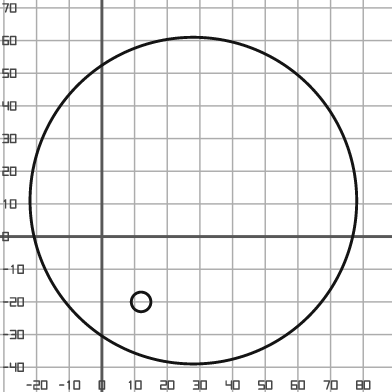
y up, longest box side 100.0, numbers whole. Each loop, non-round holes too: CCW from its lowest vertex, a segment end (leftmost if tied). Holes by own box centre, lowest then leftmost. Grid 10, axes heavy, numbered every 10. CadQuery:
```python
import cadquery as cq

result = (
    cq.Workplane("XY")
    .moveTo(28.0, 11.0)
    .circle(50.0)
    .moveTo(12.0, -20.0)
    .circle(3.0)
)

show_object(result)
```